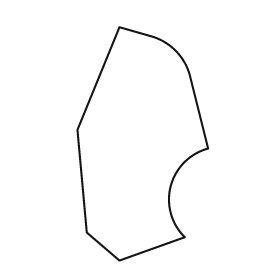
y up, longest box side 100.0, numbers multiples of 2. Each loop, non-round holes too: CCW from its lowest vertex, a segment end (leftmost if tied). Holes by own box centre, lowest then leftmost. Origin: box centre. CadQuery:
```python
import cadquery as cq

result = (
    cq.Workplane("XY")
    .moveTo(-10.0, -50.0)
    .lineTo(18.0, -40.0)
    .threePointArc((12.0, -18.0), (28.0, -2.0))
    .lineTo(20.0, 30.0)
    .threePointArc((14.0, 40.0), (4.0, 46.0))
    .lineTo(-10.0, 50.0)
    .lineTo(-28.0, 6.0)
    .lineTo(-24.0, -38.0)
    .close()
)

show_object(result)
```